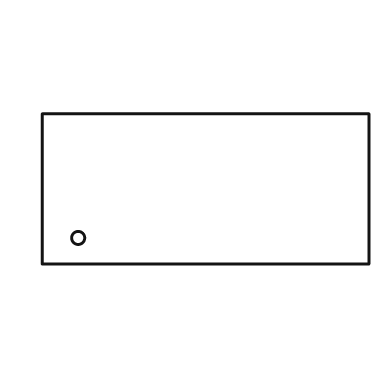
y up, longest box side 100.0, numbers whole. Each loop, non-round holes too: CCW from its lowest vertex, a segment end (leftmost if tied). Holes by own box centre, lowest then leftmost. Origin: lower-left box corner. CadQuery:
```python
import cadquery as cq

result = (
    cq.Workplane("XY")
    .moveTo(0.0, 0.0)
    .lineTo(100.0, 0.0)
    .lineTo(100.0, 46.0)
    .lineTo(0.0, 46.0)
    .close()
    .moveTo(11.0, 8.0)
    .circle(2.0)
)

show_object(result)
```